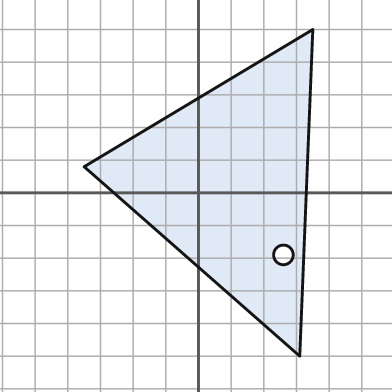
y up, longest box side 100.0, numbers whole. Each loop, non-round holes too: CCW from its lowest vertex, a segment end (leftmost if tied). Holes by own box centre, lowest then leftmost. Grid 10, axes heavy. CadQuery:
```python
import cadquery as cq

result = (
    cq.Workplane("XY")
    .moveTo(31.0, -50.0)
    .lineTo(35.0, 50.0)
    .lineTo(-35.0, 8.0)
    .close()
    .moveTo(26.0, -19.0)
    .circle(3.0)
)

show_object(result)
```